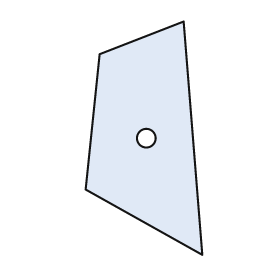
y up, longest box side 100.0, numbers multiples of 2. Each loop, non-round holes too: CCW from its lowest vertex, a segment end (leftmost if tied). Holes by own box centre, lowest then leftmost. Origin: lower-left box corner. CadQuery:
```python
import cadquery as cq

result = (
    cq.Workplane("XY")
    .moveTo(50.0, 0.0)
    .lineTo(42.0, 100.0)
    .lineTo(6.0, 86.0)
    .lineTo(0.0, 28.0)
    .close()
    .moveTo(26.0, 50.0)
    .circle(4.0)
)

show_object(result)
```